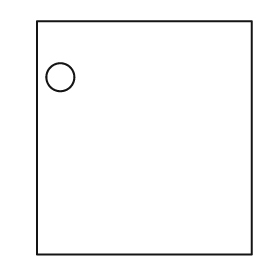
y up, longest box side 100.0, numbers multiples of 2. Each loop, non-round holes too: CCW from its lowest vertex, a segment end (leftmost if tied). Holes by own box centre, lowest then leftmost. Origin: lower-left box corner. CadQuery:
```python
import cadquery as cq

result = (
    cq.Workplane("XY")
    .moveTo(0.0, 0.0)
    .lineTo(92.0, 0.0)
    .lineTo(92.0, 100.0)
    .lineTo(0.0, 100.0)
    .close()
    .moveTo(10.0, 76.0)
    .circle(6.0)
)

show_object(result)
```